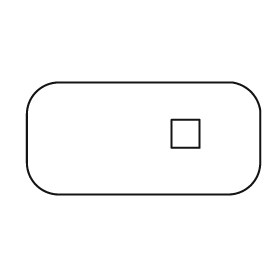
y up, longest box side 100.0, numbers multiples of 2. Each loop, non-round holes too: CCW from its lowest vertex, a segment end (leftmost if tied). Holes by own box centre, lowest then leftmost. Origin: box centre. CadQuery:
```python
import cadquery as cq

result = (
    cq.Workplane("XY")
    .moveTo(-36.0, -24.0)
    .lineTo(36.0, -24.0)
    .threePointArc((46.0, -20.0), (50.0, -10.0))
    .lineTo(50.0, 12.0)
    .threePointArc((46.0, 20.0), (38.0, 24.0))
    .lineTo(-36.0, 24.0)
    .threePointArc((-46.0, 20.0), (-50.0, 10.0))
    .lineTo(-50.0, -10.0)
    .threePointArc((-46.0, -20.0), (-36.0, -24.0))
    .close()
    .moveTo(12.0, -4.0)
    .lineTo(24.0, -4.0)
    .lineTo(24.0, 8.0)
    .lineTo(12.0, 8.0)
    .close()
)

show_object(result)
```